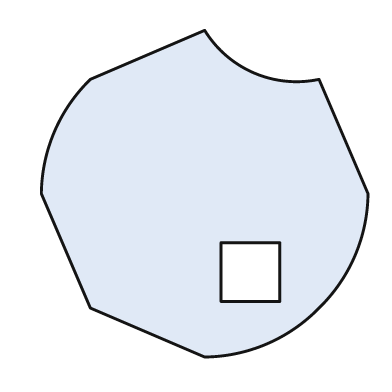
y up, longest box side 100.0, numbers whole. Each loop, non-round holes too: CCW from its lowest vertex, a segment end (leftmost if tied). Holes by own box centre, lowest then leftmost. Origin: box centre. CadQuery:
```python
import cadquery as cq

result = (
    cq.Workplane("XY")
    .moveTo(0.0, -50.0)
    .threePointArc((19.0, -46.0), (35.0, -35.0))
    .threePointArc((46.0, -19.0), (50.0, 0.0))
    .lineTo(35.0, 35.0)
    .threePointArc((15.0, 37.0), (0.0, 50.0))
    .lineTo(-35.0, 35.0)
    .threePointArc((-46.0, 19.0), (-50.0, 0.0))
    .lineTo(-35.0, -35.0)
    .close()
    .moveTo(5.0, -33.0)
    .lineTo(23.0, -33.0)
    .lineTo(23.0, -15.0)
    .lineTo(5.0, -15.0)
    .close()
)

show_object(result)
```